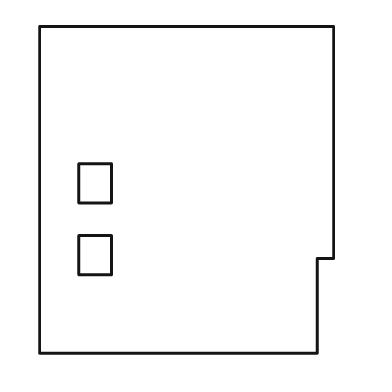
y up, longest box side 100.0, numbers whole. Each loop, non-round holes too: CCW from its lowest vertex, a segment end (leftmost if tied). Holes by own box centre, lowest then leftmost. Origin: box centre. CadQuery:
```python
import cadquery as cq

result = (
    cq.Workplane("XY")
    .moveTo(-45.0, -50.0)
    .lineTo(40.0, -50.0)
    .lineTo(40.0, -21.0)
    .lineTo(45.0, -21.0)
    .lineTo(45.0, 50.0)
    .lineTo(-45.0, 50.0)
    .close()
    .moveTo(-33.0, -26.0)
    .lineTo(-23.0, -26.0)
    .lineTo(-23.0, -14.0)
    .lineTo(-33.0, -14.0)
    .close()
    .moveTo(-33.0, -4.0)
    .lineTo(-23.0, -4.0)
    .lineTo(-23.0, 8.0)
    .lineTo(-33.0, 8.0)
    .close()
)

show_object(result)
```